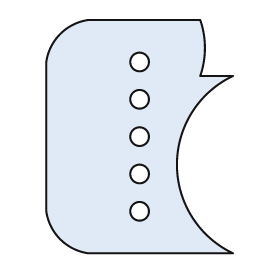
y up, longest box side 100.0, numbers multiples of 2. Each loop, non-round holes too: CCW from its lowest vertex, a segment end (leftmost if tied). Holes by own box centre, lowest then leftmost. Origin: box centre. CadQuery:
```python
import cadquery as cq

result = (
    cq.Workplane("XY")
    .moveTo(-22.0, -50.0)
    .lineTo(40.0, -50.0)
    .threePointArc((16.0, -12.0), (40.0, 26.0))
    .lineTo(26.0, 26.0)
    .threePointArc((28.0, 38.0), (26.0, 50.0))
    .lineTo(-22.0, 50.0)
    .threePointArc((-34.0, 44.0), (-40.0, 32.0))
    .lineTo(-40.0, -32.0)
    .threePointArc((-34.0, -44.0), (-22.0, -50.0))
    .close()
    .moveTo(0.0, -32.0)
    .circle(4.0)
    .moveTo(0.0, -16.0)
    .circle(4.0)
    .moveTo(0.0, 0.0)
    .circle(4.0)
    .moveTo(0.0, 16.0)
    .circle(4.0)
    .moveTo(0.0, 32.0)
    .circle(4.0)
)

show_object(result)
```